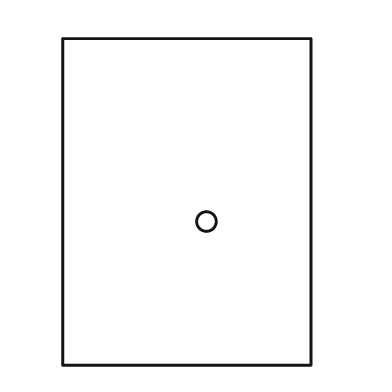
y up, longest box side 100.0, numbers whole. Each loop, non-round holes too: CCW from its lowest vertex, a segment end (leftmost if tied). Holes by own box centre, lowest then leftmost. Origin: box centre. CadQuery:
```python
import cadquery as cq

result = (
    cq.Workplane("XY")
    .moveTo(-38.0, -50.0)
    .lineTo(38.0, -50.0)
    .lineTo(38.0, 50.0)
    .lineTo(-38.0, 50.0)
    .close()
    .moveTo(6.0, -6.0)
    .circle(3.0)
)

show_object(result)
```